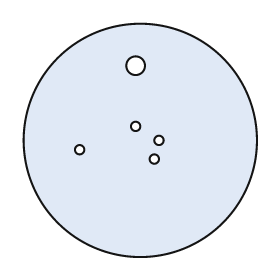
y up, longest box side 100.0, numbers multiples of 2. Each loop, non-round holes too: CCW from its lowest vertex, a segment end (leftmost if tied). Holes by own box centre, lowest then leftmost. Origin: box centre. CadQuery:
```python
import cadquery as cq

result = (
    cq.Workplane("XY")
    .moveTo(0.0, 0.0)
    .circle(50.0)
    .moveTo(6.0, -8.0)
    .circle(2.0)
    .moveTo(-26.0, -4.0)
    .circle(2.0)
    .moveTo(8.0, 0.0)
    .circle(2.0)
    .moveTo(-2.0, 6.0)
    .circle(2.0)
    .moveTo(-2.0, 32.0)
    .circle(4.0)
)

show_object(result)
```